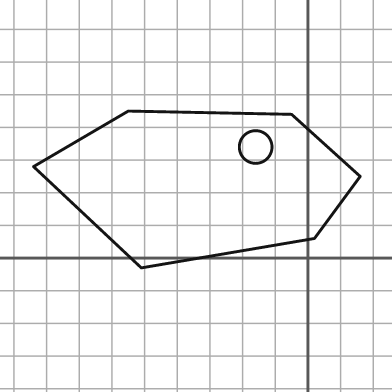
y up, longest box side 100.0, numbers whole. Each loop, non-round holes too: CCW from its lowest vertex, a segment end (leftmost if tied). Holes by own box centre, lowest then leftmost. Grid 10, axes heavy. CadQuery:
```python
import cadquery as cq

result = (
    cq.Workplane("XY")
    .moveTo(-51.0, -3.0)
    .lineTo(2.0, 6.0)
    .lineTo(16.0, 25.0)
    .lineTo(-5.0, 44.0)
    .lineTo(-55.0, 45.0)
    .lineTo(-84.0, 28.0)
    .close()
    .moveTo(-16.0, 34.0)
    .circle(5.0)
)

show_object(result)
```